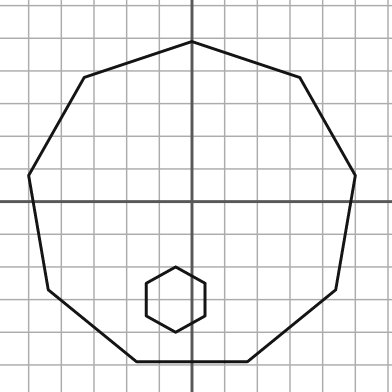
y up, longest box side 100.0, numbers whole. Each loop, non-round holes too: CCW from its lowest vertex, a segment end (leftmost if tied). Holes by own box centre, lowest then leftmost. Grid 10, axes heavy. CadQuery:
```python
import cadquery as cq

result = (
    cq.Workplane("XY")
    .moveTo(-17.0, -49.0)
    .lineTo(17.0, -49.0)
    .lineTo(44.0, -27.0)
    .lineTo(50.0, 8.0)
    .lineTo(33.0, 38.0)
    .lineTo(0.0, 49.0)
    .lineTo(-33.0, 38.0)
    .lineTo(-50.0, 8.0)
    .lineTo(-44.0, -27.0)
    .close()
    .moveTo(-5.0, -40.0)
    .lineTo(4.0, -35.0)
    .lineTo(4.0, -25.0)
    .lineTo(-5.0, -20.0)
    .lineTo(-14.0, -25.0)
    .lineTo(-14.0, -35.0)
    .close()
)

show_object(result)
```